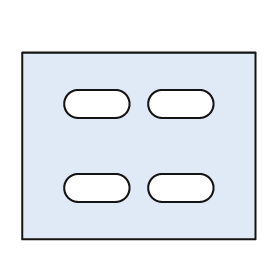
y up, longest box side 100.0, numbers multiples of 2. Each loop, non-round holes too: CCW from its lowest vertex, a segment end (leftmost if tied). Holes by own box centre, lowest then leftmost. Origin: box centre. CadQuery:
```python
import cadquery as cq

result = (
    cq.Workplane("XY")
    .moveTo(-50.0, -40.0)
    .lineTo(50.0, -40.0)
    .lineTo(50.0, 40.0)
    .lineTo(-50.0, 40.0)
    .close()
    .moveTo(-26.0, -24.0)
    .lineTo(-10.0, -24.0)
    .threePointArc((-4.0, -18.0), (-10.0, -12.0))
    .lineTo(-26.0, -12.0)
    .threePointArc((-32.0, -18.0), (-26.0, -24.0))
    .close()
    .moveTo(10.0, -24.0)
    .lineTo(26.0, -24.0)
    .threePointArc((32.0, -18.0), (26.0, -12.0))
    .lineTo(10.0, -12.0)
    .threePointArc((4.0, -18.0), (10.0, -24.0))
    .close()
    .moveTo(-26.0, 12.0)
    .lineTo(-10.0, 12.0)
    .threePointArc((-4.0, 18.0), (-10.0, 24.0))
    .lineTo(-26.0, 24.0)
    .threePointArc((-32.0, 18.0), (-26.0, 12.0))
    .close()
    .moveTo(10.0, 12.0)
    .lineTo(26.0, 12.0)
    .threePointArc((32.0, 18.0), (26.0, 24.0))
    .lineTo(10.0, 24.0)
    .threePointArc((4.0, 18.0), (10.0, 12.0))
    .close()
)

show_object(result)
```